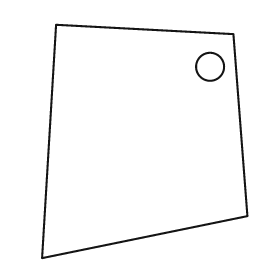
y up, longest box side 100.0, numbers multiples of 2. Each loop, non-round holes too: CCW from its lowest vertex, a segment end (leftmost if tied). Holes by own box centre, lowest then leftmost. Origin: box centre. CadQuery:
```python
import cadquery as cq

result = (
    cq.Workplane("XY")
    .moveTo(-44.0, -50.0)
    .lineTo(44.0, -32.0)
    .lineTo(38.0, 46.0)
    .lineTo(-38.0, 50.0)
    .close()
    .moveTo(28.0, 32.0)
    .circle(6.0)
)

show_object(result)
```